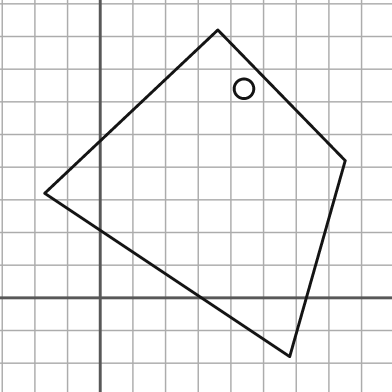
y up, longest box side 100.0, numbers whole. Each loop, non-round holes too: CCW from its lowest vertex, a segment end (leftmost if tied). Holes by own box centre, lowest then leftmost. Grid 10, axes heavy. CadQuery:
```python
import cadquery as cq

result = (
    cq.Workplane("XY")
    .moveTo(58.0, -18.0)
    .lineTo(75.0, 42.0)
    .lineTo(36.0, 82.0)
    .lineTo(-17.0, 32.0)
    .close()
    .moveTo(44.0, 64.0)
    .circle(3.0)
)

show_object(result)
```